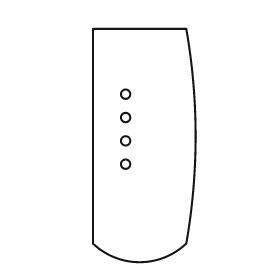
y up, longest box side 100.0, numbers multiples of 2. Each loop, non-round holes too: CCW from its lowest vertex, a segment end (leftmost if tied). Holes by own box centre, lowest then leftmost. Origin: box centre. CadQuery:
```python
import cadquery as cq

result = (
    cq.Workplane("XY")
    .moveTo(-22.0, -42.0)
    .threePointArc((-2.0, -50.0), (18.0, -42.0))
    .threePointArc((22.0, 4.0), (18.0, 50.0))
    .lineTo(-22.0, 50.0)
    .close()
    .moveTo(-8.0, -8.0)
    .circle(2.0)
    .moveTo(-8.0, 2.0)
    .circle(2.0)
    .moveTo(-8.0, 12.0)
    .circle(2.0)
    .moveTo(-8.0, 22.0)
    .circle(2.0)
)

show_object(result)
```